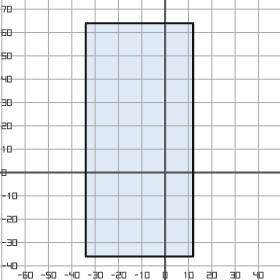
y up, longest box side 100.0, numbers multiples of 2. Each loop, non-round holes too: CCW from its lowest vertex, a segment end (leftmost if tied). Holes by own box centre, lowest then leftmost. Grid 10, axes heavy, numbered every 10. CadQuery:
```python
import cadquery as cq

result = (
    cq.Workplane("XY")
    .moveTo(-34.0, -36.0)
    .lineTo(12.0, -36.0)
    .lineTo(12.0, 64.0)
    .lineTo(-34.0, 64.0)
    .close()
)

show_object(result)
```